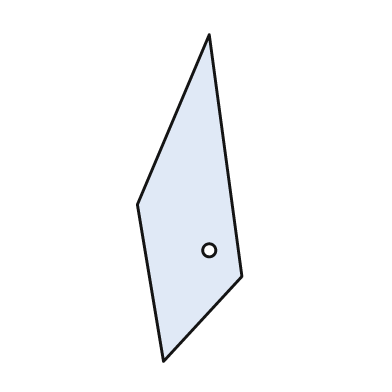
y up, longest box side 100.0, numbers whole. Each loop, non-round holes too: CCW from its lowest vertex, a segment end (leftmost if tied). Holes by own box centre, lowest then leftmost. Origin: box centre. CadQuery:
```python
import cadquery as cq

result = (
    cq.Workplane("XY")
    .moveTo(-8.0, -50.0)
    .lineTo(16.0, -24.0)
    .lineTo(6.0, 50.0)
    .lineTo(-16.0, -2.0)
    .close()
    .moveTo(6.0, -16.0)
    .circle(2.0)
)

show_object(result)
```